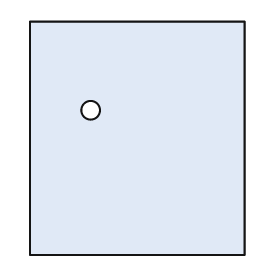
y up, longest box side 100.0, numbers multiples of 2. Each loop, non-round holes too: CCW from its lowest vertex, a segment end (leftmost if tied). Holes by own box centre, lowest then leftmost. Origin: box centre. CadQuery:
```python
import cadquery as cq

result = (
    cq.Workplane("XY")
    .moveTo(-46.0, -50.0)
    .lineTo(46.0, -50.0)
    .lineTo(46.0, 50.0)
    .lineTo(-46.0, 50.0)
    .close()
    .moveTo(-20.0, 12.0)
    .circle(4.0)
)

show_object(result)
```